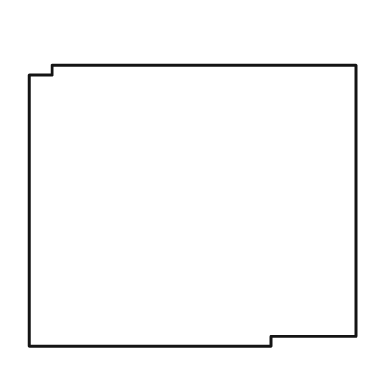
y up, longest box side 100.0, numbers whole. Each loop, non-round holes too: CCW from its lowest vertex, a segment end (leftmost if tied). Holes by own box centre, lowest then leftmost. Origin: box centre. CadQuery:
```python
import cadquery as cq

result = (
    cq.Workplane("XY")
    .moveTo(-50.0, -43.0)
    .lineTo(24.0, -43.0)
    .lineTo(24.0, -40.0)
    .lineTo(50.0, -40.0)
    .lineTo(50.0, 43.0)
    .lineTo(-43.0, 43.0)
    .lineTo(-43.0, 40.0)
    .lineTo(-50.0, 40.0)
    .close()
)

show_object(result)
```